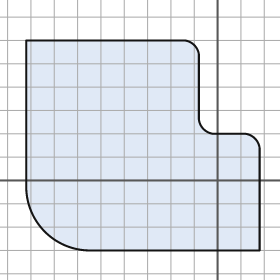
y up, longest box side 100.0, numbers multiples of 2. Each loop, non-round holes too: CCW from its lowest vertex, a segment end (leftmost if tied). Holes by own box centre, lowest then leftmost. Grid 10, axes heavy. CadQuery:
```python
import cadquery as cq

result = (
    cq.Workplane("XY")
    .moveTo(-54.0, -30.0)
    .lineTo(18.0, -30.0)
    .lineTo(18.0, 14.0)
    .threePointArc((16.0, 18.0), (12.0, 20.0))
    .lineTo(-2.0, 20.0)
    .threePointArc((-6.0, 22.0), (-8.0, 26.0))
    .lineTo(-8.0, 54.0)
    .threePointArc((-10.0, 58.0), (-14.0, 60.0))
    .lineTo(-82.0, 60.0)
    .lineTo(-82.0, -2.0)
    .threePointArc((-74.0, -22.0), (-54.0, -30.0))
    .close()
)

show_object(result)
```